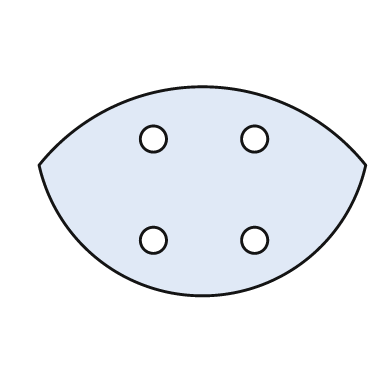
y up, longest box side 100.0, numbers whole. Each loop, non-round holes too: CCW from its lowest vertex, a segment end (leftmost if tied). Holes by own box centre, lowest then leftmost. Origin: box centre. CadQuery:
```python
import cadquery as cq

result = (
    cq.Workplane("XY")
    .moveTo(-50.0, 8.0)
    .threePointArc((0.0, -32.0), (50.0, 8.0))
    .threePointArc((0.0, 32.0), (-50.0, 8.0))
    .close()
    .moveTo(-15.0, -15.0)
    .circle(4.0)
    .moveTo(16.0, -15.0)
    .circle(4.0)
    .moveTo(-15.0, 16.0)
    .circle(4.0)
    .moveTo(16.0, 16.0)
    .circle(4.0)
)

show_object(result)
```